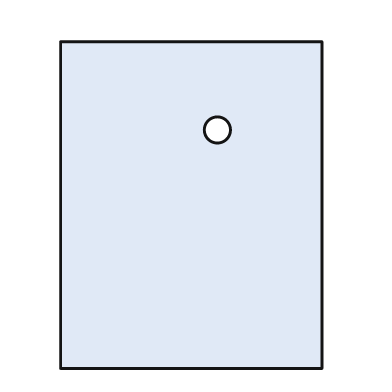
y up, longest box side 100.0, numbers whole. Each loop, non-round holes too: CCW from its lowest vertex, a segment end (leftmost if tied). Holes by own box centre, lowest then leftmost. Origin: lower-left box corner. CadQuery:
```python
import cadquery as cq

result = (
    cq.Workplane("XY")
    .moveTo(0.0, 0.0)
    .lineTo(80.0, 0.0)
    .lineTo(80.0, 100.0)
    .lineTo(0.0, 100.0)
    .close()
    .moveTo(48.0, 73.0)
    .circle(4.0)
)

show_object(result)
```